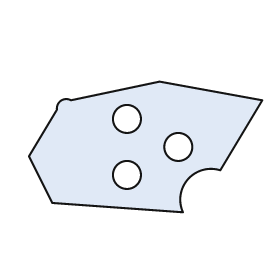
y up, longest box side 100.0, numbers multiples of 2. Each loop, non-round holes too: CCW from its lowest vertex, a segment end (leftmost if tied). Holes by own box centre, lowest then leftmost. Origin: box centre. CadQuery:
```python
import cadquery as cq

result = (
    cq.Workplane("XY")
    .moveTo(16.0, -28.0)
    .threePointArc((18.0, -14.0), (32.0, -10.0))
    .lineTo(50.0, 20.0)
    .lineTo(6.0, 28.0)
    .lineTo(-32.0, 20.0)
    .threePointArc((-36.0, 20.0), (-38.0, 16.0))
    .lineTo(-50.0, -4.0)
    .lineTo(-40.0, -24.0)
    .close()
    .moveTo(-8.0, -12.0)
    .circle(6.0)
    .moveTo(14.0, 0.0)
    .circle(6.0)
    .moveTo(-8.0, 12.0)
    .circle(6.0)
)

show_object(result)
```